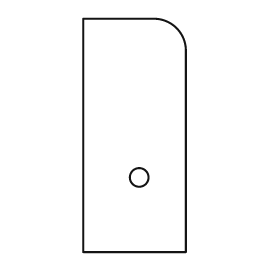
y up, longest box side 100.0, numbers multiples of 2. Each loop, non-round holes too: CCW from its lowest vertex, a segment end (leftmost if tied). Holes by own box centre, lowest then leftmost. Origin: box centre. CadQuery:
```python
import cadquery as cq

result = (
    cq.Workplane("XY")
    .moveTo(-22.0, -50.0)
    .lineTo(22.0, -50.0)
    .lineTo(22.0, 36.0)
    .threePointArc((18.0, 46.0), (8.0, 50.0))
    .lineTo(-22.0, 50.0)
    .close()
    .moveTo(2.0, -18.0)
    .circle(4.0)
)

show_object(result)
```